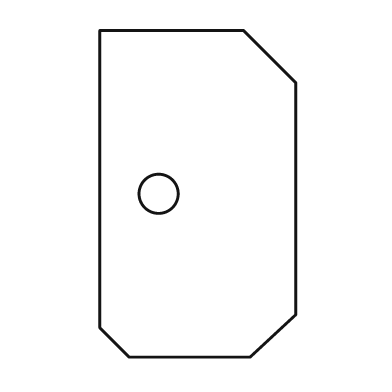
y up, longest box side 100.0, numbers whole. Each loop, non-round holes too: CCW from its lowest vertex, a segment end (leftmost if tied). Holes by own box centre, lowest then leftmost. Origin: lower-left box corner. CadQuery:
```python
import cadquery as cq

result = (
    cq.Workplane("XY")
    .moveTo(9.0, 0.0)
    .lineTo(46.0, 0.0)
    .lineTo(60.0, 13.0)
    .lineTo(60.0, 84.0)
    .lineTo(44.0, 100.0)
    .lineTo(0.0, 100.0)
    .lineTo(0.0, 9.0)
    .close()
    .moveTo(18.0, 50.0)
    .circle(6.0)
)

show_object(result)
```